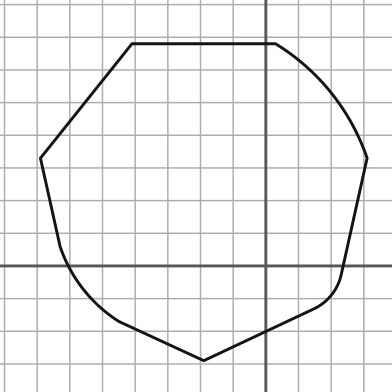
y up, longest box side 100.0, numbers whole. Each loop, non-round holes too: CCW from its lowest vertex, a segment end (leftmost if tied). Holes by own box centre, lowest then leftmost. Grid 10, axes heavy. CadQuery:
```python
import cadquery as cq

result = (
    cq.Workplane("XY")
    .moveTo(-19.0, -29.0)
    .lineTo(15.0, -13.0)
    .threePointArc((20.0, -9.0), (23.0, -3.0))
    .lineTo(31.0, 33.0)
    .threePointArc((20.0, 53.0), (3.0, 68.0))
    .lineTo(-41.0, 68.0)
    .lineTo(-69.0, 33.0)
    .lineTo(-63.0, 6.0)
    .threePointArc((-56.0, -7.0), (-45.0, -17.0))
    .close()
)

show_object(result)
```